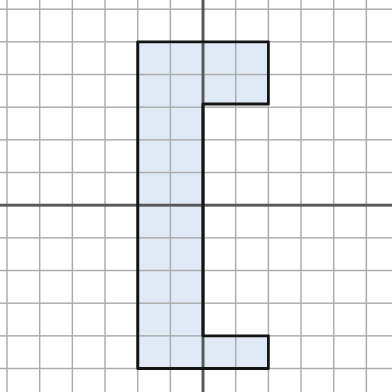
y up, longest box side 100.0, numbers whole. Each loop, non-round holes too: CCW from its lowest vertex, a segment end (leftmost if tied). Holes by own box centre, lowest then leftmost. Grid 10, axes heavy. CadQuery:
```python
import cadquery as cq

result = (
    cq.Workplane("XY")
    .moveTo(-20.0, -50.0)
    .lineTo(20.0, -50.0)
    .lineTo(20.0, -40.0)
    .lineTo(0.0, -40.0)
    .lineTo(0.0, 31.0)
    .lineTo(20.0, 31.0)
    .lineTo(20.0, 50.0)
    .lineTo(-20.0, 50.0)
    .close()
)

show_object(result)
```